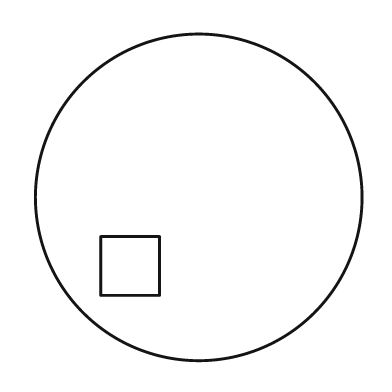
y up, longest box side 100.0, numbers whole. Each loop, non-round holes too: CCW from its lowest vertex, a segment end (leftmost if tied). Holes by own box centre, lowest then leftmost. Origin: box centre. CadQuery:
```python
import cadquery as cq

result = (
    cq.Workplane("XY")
    .moveTo(0.0, 0.0)
    .circle(50.0)
    .moveTo(-30.0, -30.0)
    .lineTo(-12.0, -30.0)
    .lineTo(-12.0, -12.0)
    .lineTo(-30.0, -12.0)
    .close()
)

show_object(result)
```